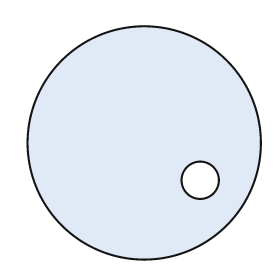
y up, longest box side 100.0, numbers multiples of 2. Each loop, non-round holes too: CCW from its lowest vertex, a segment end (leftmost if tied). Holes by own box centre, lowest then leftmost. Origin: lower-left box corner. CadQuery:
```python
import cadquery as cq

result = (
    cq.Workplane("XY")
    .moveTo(50.0, 50.0)
    .circle(50.0)
    .moveTo(74.0, 34.0)
    .circle(8.0)
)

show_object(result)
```